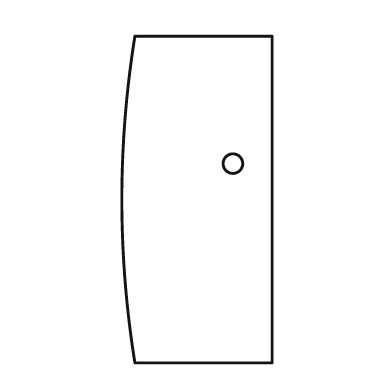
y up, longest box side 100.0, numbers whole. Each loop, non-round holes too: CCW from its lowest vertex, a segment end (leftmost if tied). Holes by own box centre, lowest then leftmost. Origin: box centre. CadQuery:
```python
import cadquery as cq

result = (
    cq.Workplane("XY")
    .moveTo(-19.0, -50.0)
    .lineTo(23.0, -50.0)
    .lineTo(23.0, 50.0)
    .lineTo(-19.0, 50.0)
    .threePointArc((-23.0, 0.0), (-19.0, -50.0))
    .close()
    .moveTo(11.0, 11.0)
    .circle(3.0)
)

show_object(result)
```